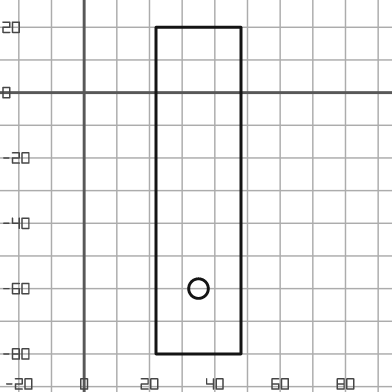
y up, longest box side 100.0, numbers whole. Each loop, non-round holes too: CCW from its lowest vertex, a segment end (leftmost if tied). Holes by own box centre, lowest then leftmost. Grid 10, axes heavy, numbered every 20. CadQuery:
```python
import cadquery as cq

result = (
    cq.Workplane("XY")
    .moveTo(22.0, -80.0)
    .lineTo(48.0, -80.0)
    .lineTo(48.0, 20.0)
    .lineTo(22.0, 20.0)
    .close()
    .moveTo(35.0, -60.0)
    .circle(3.0)
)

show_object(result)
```